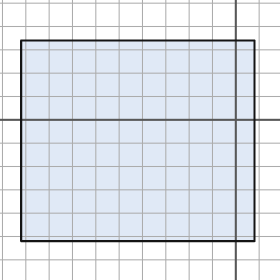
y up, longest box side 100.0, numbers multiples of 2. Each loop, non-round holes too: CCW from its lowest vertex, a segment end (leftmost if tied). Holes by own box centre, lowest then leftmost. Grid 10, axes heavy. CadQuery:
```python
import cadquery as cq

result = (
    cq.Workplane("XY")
    .moveTo(-92.0, -52.0)
    .lineTo(8.0, -52.0)
    .lineTo(8.0, 34.0)
    .lineTo(-92.0, 34.0)
    .close()
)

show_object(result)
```